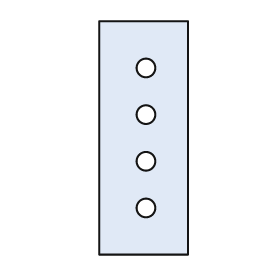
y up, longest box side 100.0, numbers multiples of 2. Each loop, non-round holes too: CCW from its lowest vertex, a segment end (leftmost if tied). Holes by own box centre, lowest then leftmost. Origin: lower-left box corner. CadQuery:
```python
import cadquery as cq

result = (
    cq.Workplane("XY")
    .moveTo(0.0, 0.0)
    .lineTo(38.0, 0.0)
    .lineTo(38.0, 100.0)
    .lineTo(0.0, 100.0)
    .close()
    .moveTo(20.0, 20.0)
    .circle(4.0)
    .moveTo(20.0, 40.0)
    .circle(4.0)
    .moveTo(20.0, 60.0)
    .circle(4.0)
    .moveTo(20.0, 80.0)
    .circle(4.0)
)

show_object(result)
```